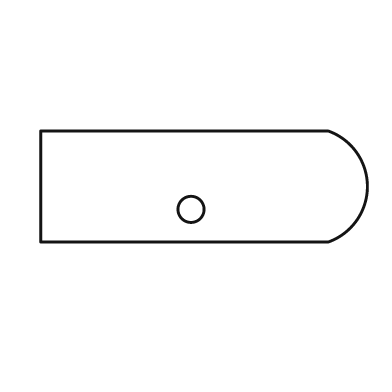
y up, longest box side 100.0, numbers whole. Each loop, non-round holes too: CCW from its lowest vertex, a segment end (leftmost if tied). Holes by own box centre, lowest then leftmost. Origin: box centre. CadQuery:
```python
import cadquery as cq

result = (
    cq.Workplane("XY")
    .moveTo(-50.0, -17.0)
    .lineTo(38.0, -17.0)
    .threePointArc((50.0, 0.0), (38.0, 17.0))
    .lineTo(-50.0, 17.0)
    .close()
    .moveTo(-4.0, -7.0)
    .circle(4.0)
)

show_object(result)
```